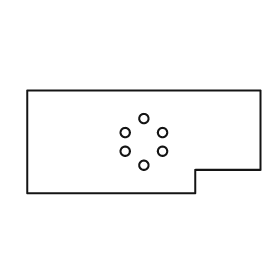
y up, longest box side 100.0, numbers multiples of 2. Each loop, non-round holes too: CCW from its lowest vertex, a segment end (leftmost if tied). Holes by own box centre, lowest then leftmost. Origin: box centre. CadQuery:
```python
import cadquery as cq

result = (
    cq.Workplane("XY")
    .moveTo(-50.0, -22.0)
    .lineTo(22.0, -22.0)
    .lineTo(22.0, -12.0)
    .lineTo(50.0, -12.0)
    .lineTo(50.0, 22.0)
    .lineTo(-50.0, 22.0)
    .close()
    .moveTo(0.0, -10.0)
    .circle(2.0)
    .moveTo(-8.0, -4.0)
    .circle(2.0)
    .moveTo(8.0, -4.0)
    .circle(2.0)
    .moveTo(-8.0, 4.0)
    .circle(2.0)
    .moveTo(8.0, 4.0)
    .circle(2.0)
    .moveTo(0.0, 10.0)
    .circle(2.0)
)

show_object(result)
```